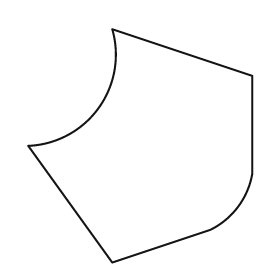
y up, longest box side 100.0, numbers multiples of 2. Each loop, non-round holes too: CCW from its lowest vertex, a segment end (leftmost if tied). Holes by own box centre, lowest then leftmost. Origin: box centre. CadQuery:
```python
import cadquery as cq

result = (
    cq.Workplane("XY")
    .moveTo(-12.0, -50.0)
    .lineTo(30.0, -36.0)
    .threePointArc((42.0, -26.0), (48.0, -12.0))
    .lineTo(48.0, 30.0)
    .lineTo(-12.0, 50.0)
    .threePointArc((-18.0, 16.0), (-48.0, 0.0))
    .close()
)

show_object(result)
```